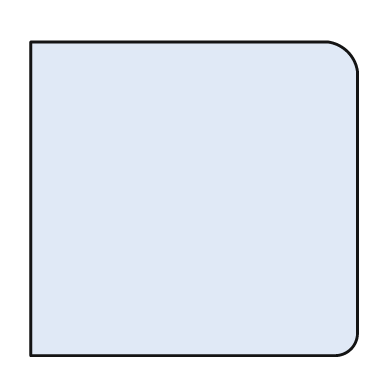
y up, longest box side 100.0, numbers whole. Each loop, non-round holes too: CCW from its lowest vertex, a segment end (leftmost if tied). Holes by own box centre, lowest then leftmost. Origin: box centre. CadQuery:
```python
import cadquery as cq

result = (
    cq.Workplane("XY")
    .moveTo(-50.0, -48.0)
    .lineTo(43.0, -48.0)
    .threePointArc((48.0, -46.0), (50.0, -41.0))
    .lineTo(50.0, 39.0)
    .threePointArc((47.0, 45.0), (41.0, 48.0))
    .lineTo(-50.0, 48.0)
    .close()
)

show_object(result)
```